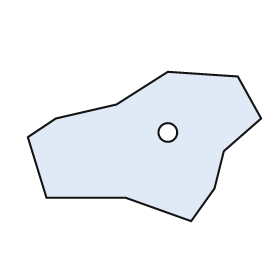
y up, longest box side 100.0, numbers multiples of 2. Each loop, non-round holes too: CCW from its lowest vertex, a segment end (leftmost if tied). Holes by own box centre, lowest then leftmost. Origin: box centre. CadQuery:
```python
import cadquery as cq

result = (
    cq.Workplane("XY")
    .moveTo(20.0, -32.0)
    .lineTo(30.0, -18.0)
    .lineTo(34.0, -2.0)
    .lineTo(50.0, 12.0)
    .lineTo(40.0, 30.0)
    .lineTo(10.0, 32.0)
    .lineTo(-12.0, 18.0)
    .lineTo(-38.0, 12.0)
    .lineTo(-50.0, 4.0)
    .lineTo(-42.0, -22.0)
    .lineTo(-8.0, -22.0)
    .close()
    .moveTo(10.0, 6.0)
    .circle(4.0)
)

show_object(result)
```